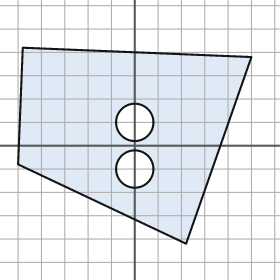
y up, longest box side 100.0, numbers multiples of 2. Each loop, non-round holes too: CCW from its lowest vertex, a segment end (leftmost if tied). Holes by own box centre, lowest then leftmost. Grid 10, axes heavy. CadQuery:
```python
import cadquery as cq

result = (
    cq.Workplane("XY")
    .moveTo(22.0, -42.0)
    .lineTo(50.0, 38.0)
    .lineTo(-48.0, 42.0)
    .lineTo(-50.0, -8.0)
    .close()
    .moveTo(0.0, -10.0)
    .circle(8.0)
    .moveTo(0.0, 10.0)
    .circle(8.0)
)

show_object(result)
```